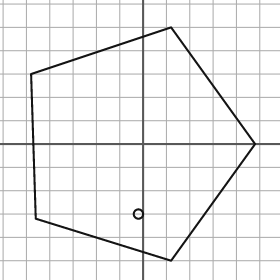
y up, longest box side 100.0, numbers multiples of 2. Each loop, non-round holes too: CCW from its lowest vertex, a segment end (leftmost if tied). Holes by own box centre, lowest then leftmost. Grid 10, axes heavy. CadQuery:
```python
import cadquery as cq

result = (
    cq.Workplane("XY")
    .moveTo(12.0, -50.0)
    .lineTo(48.0, 0.0)
    .lineTo(12.0, 50.0)
    .lineTo(-48.0, 30.0)
    .lineTo(-46.0, -32.0)
    .close()
    .moveTo(-2.0, -30.0)
    .circle(2.0)
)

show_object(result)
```